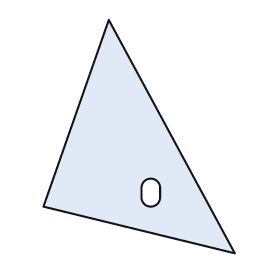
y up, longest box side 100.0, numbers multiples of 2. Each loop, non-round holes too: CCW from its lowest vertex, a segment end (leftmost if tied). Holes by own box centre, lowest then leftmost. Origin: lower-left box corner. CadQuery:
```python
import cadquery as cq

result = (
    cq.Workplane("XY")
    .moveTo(82.0, 0.0)
    .lineTo(28.0, 100.0)
    .lineTo(0.0, 20.0)
    .close()
    .moveTo(42.0, 24.0)
    .threePointArc((46.0, 20.0), (50.0, 24.0))
    .lineTo(50.0, 28.0)
    .threePointArc((46.0, 32.0), (42.0, 28.0))
    .close()
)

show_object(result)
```